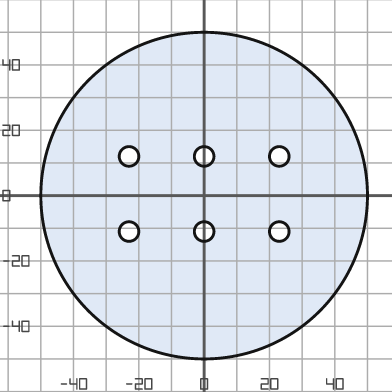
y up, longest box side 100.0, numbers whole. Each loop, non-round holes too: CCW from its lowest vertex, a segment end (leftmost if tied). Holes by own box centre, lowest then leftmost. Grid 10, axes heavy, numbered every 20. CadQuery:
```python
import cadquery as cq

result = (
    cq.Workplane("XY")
    .moveTo(0.0, 0.0)
    .circle(50.0)
    .moveTo(-23.0, -11.0)
    .circle(3.0)
    .moveTo(0.0, -11.0)
    .circle(3.0)
    .moveTo(23.0, -11.0)
    .circle(3.0)
    .moveTo(-23.0, 12.0)
    .circle(3.0)
    .moveTo(0.0, 12.0)
    .circle(3.0)
    .moveTo(23.0, 12.0)
    .circle(3.0)
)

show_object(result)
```